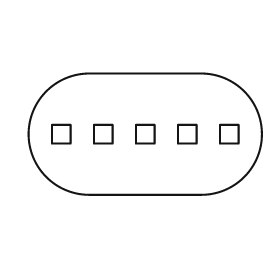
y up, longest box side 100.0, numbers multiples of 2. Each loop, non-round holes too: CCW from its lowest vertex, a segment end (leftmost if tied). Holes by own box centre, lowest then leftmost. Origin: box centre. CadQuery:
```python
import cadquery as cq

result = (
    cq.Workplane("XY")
    .moveTo(-24.0, -26.0)
    .lineTo(24.0, -26.0)
    .threePointArc((50.0, 0.0), (24.0, 26.0))
    .lineTo(-24.0, 26.0)
    .threePointArc((-50.0, 0.0), (-24.0, -26.0))
    .close()
    .moveTo(-40.0, -4.0)
    .lineTo(-32.0, -4.0)
    .lineTo(-32.0, 4.0)
    .lineTo(-40.0, 4.0)
    .close()
    .moveTo(-22.0, -4.0)
    .lineTo(-14.0, -4.0)
    .lineTo(-14.0, 4.0)
    .lineTo(-22.0, 4.0)
    .close()
    .moveTo(-4.0, -4.0)
    .lineTo(4.0, -4.0)
    .lineTo(4.0, 4.0)
    .lineTo(-4.0, 4.0)
    .close()
    .moveTo(14.0, -4.0)
    .lineTo(22.0, -4.0)
    .lineTo(22.0, 4.0)
    .lineTo(14.0, 4.0)
    .close()
    .moveTo(32.0, -4.0)
    .lineTo(40.0, -4.0)
    .lineTo(40.0, 4.0)
    .lineTo(32.0, 4.0)
    .close()
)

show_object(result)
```